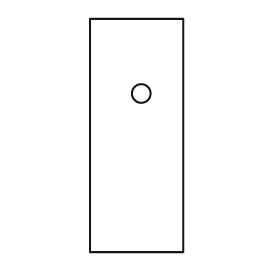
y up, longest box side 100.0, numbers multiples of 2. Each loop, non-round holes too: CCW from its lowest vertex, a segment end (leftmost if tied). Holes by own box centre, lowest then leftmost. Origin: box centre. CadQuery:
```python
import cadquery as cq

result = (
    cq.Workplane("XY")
    .moveTo(-20.0, -50.0)
    .lineTo(20.0, -50.0)
    .lineTo(20.0, 50.0)
    .lineTo(-20.0, 50.0)
    .close()
    .moveTo(2.0, 18.0)
    .circle(4.0)
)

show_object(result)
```